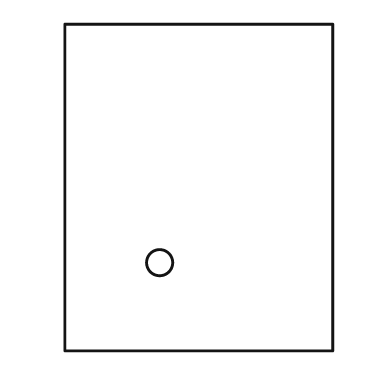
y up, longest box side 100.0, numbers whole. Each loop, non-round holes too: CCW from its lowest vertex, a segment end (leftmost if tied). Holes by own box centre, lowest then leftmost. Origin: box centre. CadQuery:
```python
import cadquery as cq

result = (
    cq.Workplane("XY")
    .moveTo(-41.0, -50.0)
    .lineTo(41.0, -50.0)
    .lineTo(41.0, 50.0)
    .lineTo(-41.0, 50.0)
    .close()
    .moveTo(-12.0, -23.0)
    .circle(4.0)
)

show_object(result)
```